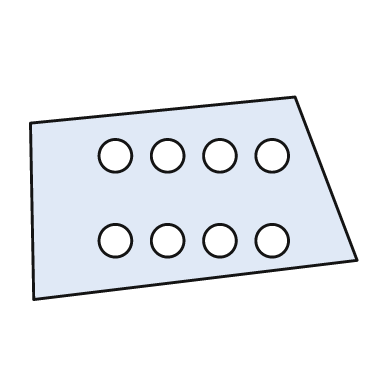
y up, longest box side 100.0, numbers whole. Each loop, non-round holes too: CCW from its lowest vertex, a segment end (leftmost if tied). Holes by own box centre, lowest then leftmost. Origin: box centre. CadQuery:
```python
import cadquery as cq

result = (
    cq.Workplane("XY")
    .moveTo(-49.0, -31.0)
    .lineTo(50.0, -19.0)
    .lineTo(31.0, 31.0)
    .lineTo(-50.0, 23.0)
    .close()
    .moveTo(-24.0, -13.0)
    .circle(5.0)
    .moveTo(-8.0, -13.0)
    .circle(5.0)
    .moveTo(8.0, -13.0)
    .circle(5.0)
    .moveTo(24.0, -13.0)
    .circle(5.0)
    .moveTo(-24.0, 13.0)
    .circle(5.0)
    .moveTo(-8.0, 13.0)
    .circle(5.0)
    .moveTo(8.0, 13.0)
    .circle(5.0)
    .moveTo(24.0, 13.0)
    .circle(5.0)
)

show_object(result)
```